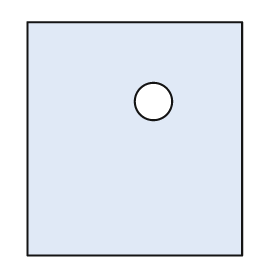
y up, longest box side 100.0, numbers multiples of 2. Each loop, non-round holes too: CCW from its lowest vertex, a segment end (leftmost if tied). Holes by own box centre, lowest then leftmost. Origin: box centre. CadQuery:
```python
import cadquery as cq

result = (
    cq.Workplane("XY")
    .moveTo(-46.0, -50.0)
    .lineTo(46.0, -50.0)
    .lineTo(46.0, 50.0)
    .lineTo(-46.0, 50.0)
    .close()
    .moveTo(8.0, 16.0)
    .circle(8.0)
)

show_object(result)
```